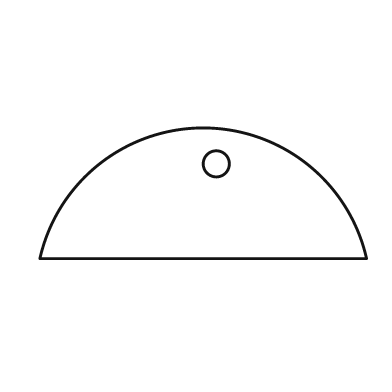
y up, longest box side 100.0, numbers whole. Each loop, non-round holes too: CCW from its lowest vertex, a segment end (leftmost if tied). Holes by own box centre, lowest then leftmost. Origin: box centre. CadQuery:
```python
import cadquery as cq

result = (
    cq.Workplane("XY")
    .moveTo(-50.0, -20.0)
    .lineTo(50.0, -20.0)
    .threePointArc((0.0, 20.0), (-50.0, -20.0))
    .close()
    .moveTo(4.0, 9.0)
    .circle(4.0)
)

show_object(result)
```